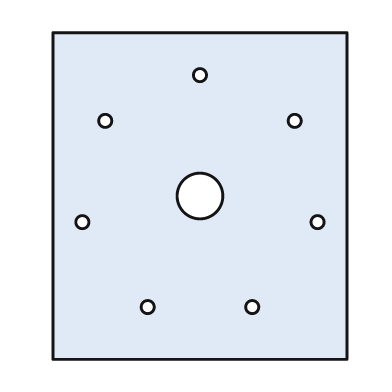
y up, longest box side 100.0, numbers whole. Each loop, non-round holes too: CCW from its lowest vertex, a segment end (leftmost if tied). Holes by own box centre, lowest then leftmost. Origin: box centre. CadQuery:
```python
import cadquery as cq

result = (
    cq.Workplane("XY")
    .moveTo(-45.0, -50.0)
    .lineTo(45.0, -50.0)
    .lineTo(45.0, 50.0)
    .lineTo(-45.0, 50.0)
    .close()
    .moveTo(-16.0, -34.0)
    .circle(2.0)
    .moveTo(16.0, -34.0)
    .circle(2.0)
    .moveTo(-36.0, -8.0)
    .circle(2.0)
    .moveTo(36.0, -8.0)
    .circle(2.0)
    .moveTo(0.0, 0.0)
    .circle(7.0)
    .moveTo(-29.0, 23.0)
    .circle(2.0)
    .moveTo(29.0, 23.0)
    .circle(2.0)
    .moveTo(0.0, 37.0)
    .circle(2.0)
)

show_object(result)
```